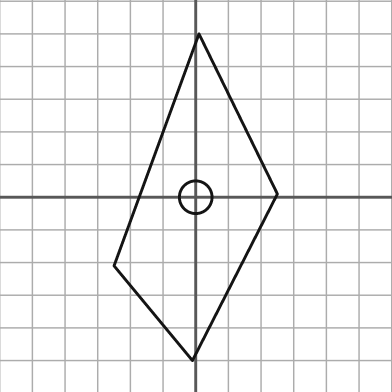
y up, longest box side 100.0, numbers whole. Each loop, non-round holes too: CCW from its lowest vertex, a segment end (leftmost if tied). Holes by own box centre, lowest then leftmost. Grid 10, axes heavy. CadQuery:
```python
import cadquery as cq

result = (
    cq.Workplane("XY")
    .moveTo(-1.0, -50.0)
    .lineTo(25.0, 1.0)
    .lineTo(1.0, 50.0)
    .lineTo(-25.0, -21.0)
    .close()
    .moveTo(0.0, 0.0)
    .circle(5.0)
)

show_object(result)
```